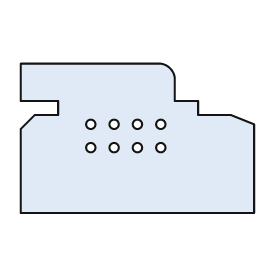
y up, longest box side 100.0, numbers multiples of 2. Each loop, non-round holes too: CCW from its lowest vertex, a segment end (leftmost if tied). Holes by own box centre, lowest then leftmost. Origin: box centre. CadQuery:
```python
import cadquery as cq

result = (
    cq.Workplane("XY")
    .moveTo(-50.0, -32.0)
    .lineTo(50.0, -32.0)
    .lineTo(50.0, 6.0)
    .lineTo(40.0, 10.0)
    .lineTo(26.0, 10.0)
    .lineTo(26.0, 16.0)
    .lineTo(16.0, 16.0)
    .lineTo(16.0, 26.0)
    .threePointArc((14.0, 30.0), (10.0, 32.0))
    .lineTo(-50.0, 32.0)
    .lineTo(-50.0, 16.0)
    .lineTo(-34.0, 16.0)
    .lineTo(-34.0, 10.0)
    .lineTo(-44.0, 10.0)
    .lineTo(-50.0, 4.0)
    .close()
    .moveTo(-20.0, -4.0)
    .circle(2.0)
    .moveTo(-10.0, -4.0)
    .circle(2.0)
    .moveTo(0.0, -4.0)
    .circle(2.0)
    .moveTo(10.0, -4.0)
    .circle(2.0)
    .moveTo(-20.0, 6.0)
    .circle(2.0)
    .moveTo(-10.0, 6.0)
    .circle(2.0)
    .moveTo(0.0, 6.0)
    .circle(2.0)
    .moveTo(10.0, 6.0)
    .circle(2.0)
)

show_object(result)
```